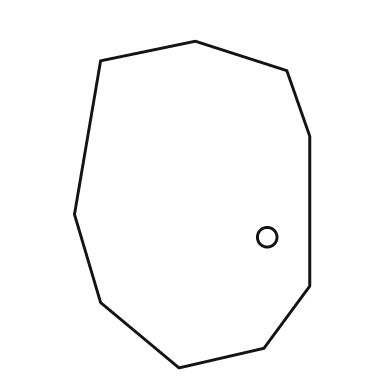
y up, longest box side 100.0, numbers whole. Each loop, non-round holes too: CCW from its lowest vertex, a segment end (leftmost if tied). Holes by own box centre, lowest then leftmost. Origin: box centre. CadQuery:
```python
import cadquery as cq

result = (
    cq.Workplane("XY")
    .moveTo(-4.0, -50.0)
    .lineTo(22.0, -44.0)
    .lineTo(36.0, -25.0)
    .lineTo(36.0, 21.0)
    .lineTo(29.0, 41.0)
    .lineTo(1.0, 50.0)
    .lineTo(-28.0, 44.0)
    .lineTo(-36.0, -3.0)
    .lineTo(-28.0, -30.0)
    .close()
    .moveTo(23.0, -10.0)
    .circle(3.0)
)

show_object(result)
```